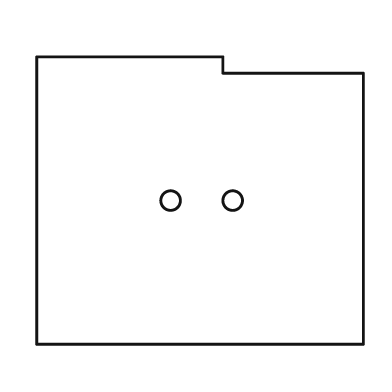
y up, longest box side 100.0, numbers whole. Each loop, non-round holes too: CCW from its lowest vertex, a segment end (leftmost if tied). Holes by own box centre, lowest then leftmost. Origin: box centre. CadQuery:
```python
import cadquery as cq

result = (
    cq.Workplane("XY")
    .moveTo(-50.0, -44.0)
    .lineTo(50.0, -44.0)
    .lineTo(50.0, 39.0)
    .lineTo(7.0, 39.0)
    .lineTo(7.0, 44.0)
    .lineTo(-50.0, 44.0)
    .close()
    .moveTo(-9.0, 0.0)
    .circle(3.0)
    .moveTo(10.0, 0.0)
    .circle(3.0)
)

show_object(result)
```